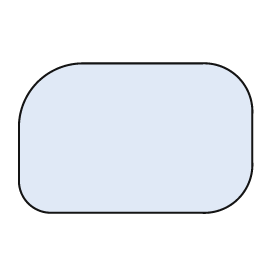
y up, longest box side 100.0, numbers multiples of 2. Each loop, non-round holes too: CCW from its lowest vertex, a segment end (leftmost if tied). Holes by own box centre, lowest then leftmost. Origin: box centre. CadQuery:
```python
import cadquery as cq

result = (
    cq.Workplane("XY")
    .moveTo(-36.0, -32.0)
    .lineTo(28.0, -32.0)
    .threePointArc((44.0, -26.0), (50.0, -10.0))
    .lineTo(50.0, 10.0)
    .threePointArc((44.0, 26.0), (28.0, 32.0))
    .lineTo(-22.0, 32.0)
    .threePointArc((-42.0, 24.0), (-50.0, 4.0))
    .lineTo(-50.0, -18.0)
    .threePointArc((-46.0, -28.0), (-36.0, -32.0))
    .close()
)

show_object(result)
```